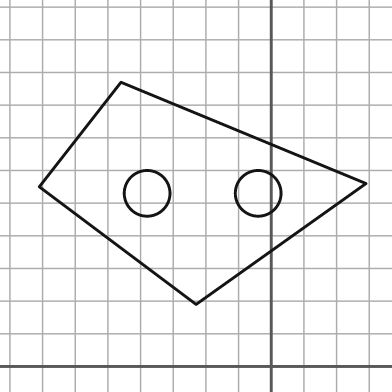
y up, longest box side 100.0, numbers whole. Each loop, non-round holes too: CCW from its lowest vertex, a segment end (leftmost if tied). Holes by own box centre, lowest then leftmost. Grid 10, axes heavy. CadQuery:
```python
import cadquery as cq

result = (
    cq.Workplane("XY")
    .moveTo(-23.0, 19.0)
    .lineTo(29.0, 56.0)
    .lineTo(-46.0, 87.0)
    .lineTo(-71.0, 55.0)
    .close()
    .moveTo(-38.0, 53.0)
    .circle(7.0)
    .moveTo(-4.0, 53.0)
    .circle(7.0)
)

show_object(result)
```